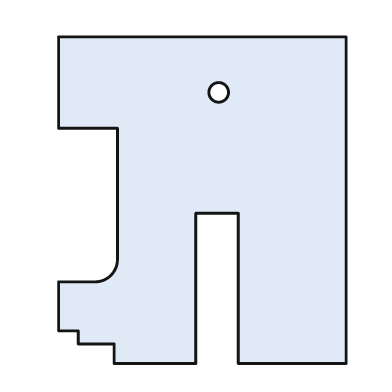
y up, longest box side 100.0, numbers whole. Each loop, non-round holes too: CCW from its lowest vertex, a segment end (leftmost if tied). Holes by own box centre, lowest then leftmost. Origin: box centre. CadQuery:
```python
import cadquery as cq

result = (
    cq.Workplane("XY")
    .moveTo(-27.0, -50.0)
    .lineTo(-2.0, -50.0)
    .lineTo(-2.0, -4.0)
    .lineTo(11.0, -4.0)
    .lineTo(11.0, -50.0)
    .lineTo(44.0, -50.0)
    .lineTo(44.0, 50.0)
    .lineTo(-44.0, 50.0)
    .lineTo(-44.0, 22.0)
    .lineTo(-26.0, 22.0)
    .lineTo(-26.0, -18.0)
    .threePointArc((-28.0, -23.0), (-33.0, -25.0))
    .lineTo(-44.0, -25.0)
    .lineTo(-44.0, -40.0)
    .lineTo(-38.0, -40.0)
    .lineTo(-38.0, -44.0)
    .lineTo(-27.0, -44.0)
    .close()
    .moveTo(5.0, 33.0)
    .circle(3.0)
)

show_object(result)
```